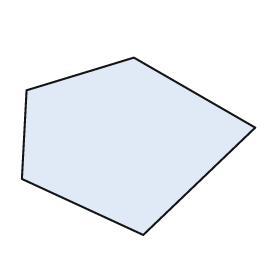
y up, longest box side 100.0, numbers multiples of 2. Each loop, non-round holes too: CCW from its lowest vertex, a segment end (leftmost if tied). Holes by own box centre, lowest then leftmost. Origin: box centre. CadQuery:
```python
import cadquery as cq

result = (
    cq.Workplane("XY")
    .moveTo(2.0, -38.0)
    .lineTo(50.0, 8.0)
    .lineTo(-2.0, 38.0)
    .lineTo(-48.0, 24.0)
    .lineTo(-50.0, -14.0)
    .close()
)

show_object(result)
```